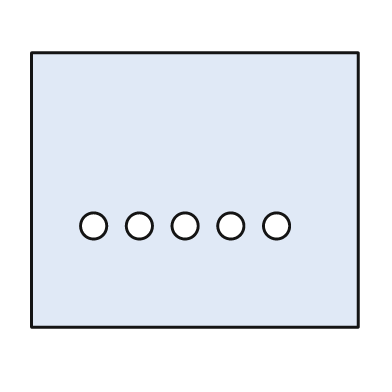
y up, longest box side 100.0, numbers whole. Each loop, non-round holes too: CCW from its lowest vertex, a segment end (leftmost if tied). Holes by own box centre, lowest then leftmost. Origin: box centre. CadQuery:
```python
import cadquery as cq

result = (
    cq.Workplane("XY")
    .moveTo(-50.0, -42.0)
    .lineTo(50.0, -42.0)
    .lineTo(50.0, 42.0)
    .lineTo(-50.0, 42.0)
    .close()
    .moveTo(-31.0, -11.0)
    .circle(4.0)
    .moveTo(-17.0, -11.0)
    .circle(4.0)
    .moveTo(-3.0, -11.0)
    .circle(4.0)
    .moveTo(11.0, -11.0)
    .circle(4.0)
    .moveTo(25.0, -11.0)
    .circle(4.0)
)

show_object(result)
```